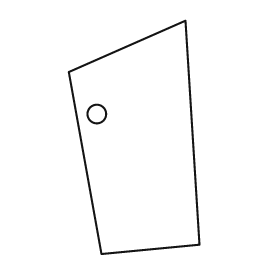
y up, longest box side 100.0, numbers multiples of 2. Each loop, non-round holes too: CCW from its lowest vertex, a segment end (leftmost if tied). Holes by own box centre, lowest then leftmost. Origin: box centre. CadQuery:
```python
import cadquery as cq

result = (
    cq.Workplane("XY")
    .moveTo(-14.0, -50.0)
    .lineTo(28.0, -46.0)
    .lineTo(22.0, 50.0)
    .lineTo(-28.0, 28.0)
    .close()
    .moveTo(-16.0, 10.0)
    .circle(4.0)
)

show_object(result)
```